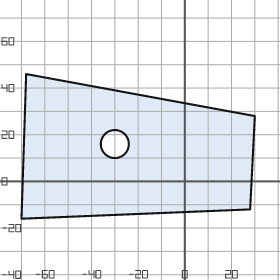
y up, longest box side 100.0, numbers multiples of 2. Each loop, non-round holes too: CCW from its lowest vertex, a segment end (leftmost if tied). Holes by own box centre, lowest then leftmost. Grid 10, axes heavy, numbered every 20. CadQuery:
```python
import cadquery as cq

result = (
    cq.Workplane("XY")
    .moveTo(-70.0, -16.0)
    .lineTo(28.0, -12.0)
    .lineTo(30.0, 28.0)
    .lineTo(-68.0, 46.0)
    .close()
    .moveTo(-30.0, 16.0)
    .circle(6.0)
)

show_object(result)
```